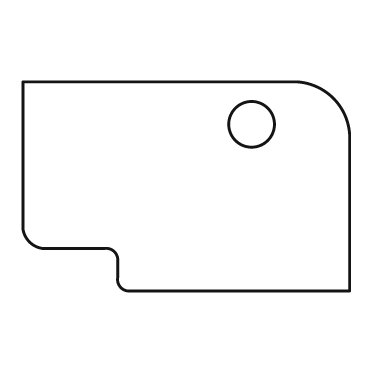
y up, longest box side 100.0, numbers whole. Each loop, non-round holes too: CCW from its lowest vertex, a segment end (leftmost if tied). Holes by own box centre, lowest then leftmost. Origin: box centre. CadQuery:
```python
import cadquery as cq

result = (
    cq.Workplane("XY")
    .moveTo(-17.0, -32.0)
    .lineTo(50.0, -32.0)
    .lineTo(50.0, 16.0)
    .threePointArc((45.0, 27.0), (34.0, 32.0))
    .lineTo(-50.0, 32.0)
    .lineTo(-50.0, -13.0)
    .threePointArc((-48.0, -17.0), (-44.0, -19.0))
    .lineTo(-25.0, -19.0)
    .threePointArc((-22.0, -20.0), (-21.0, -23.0))
    .lineTo(-21.0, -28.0)
    .threePointArc((-20.0, -31.0), (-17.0, -32.0))
    .close()
    .moveTo(20.0, 19.0)
    .circle(7.0)
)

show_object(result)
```